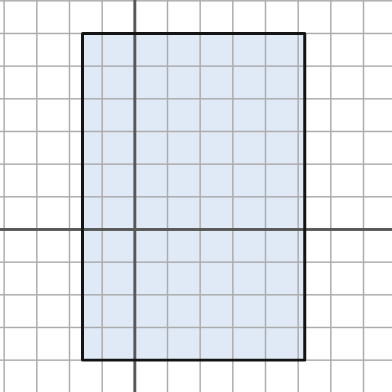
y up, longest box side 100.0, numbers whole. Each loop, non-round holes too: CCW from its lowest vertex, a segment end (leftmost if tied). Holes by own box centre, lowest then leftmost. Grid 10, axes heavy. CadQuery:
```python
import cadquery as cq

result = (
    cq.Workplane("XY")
    .moveTo(-16.0, -40.0)
    .lineTo(52.0, -40.0)
    .lineTo(52.0, 60.0)
    .lineTo(-16.0, 60.0)
    .close()
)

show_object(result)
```